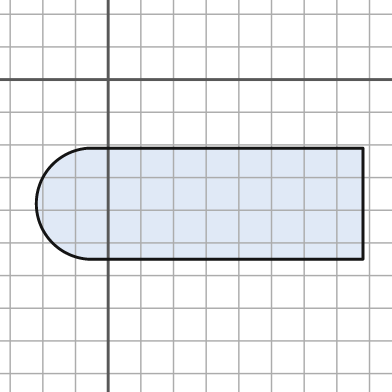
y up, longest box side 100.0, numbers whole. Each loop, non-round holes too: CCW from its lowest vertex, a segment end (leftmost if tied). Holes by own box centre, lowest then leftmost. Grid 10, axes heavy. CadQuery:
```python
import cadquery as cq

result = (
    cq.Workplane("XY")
    .moveTo(-6.0, -55.0)
    .lineTo(78.0, -55.0)
    .lineTo(78.0, -21.0)
    .lineTo(-6.0, -21.0)
    .threePointArc((-22.0, -38.0), (-6.0, -55.0))
    .close()
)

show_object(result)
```